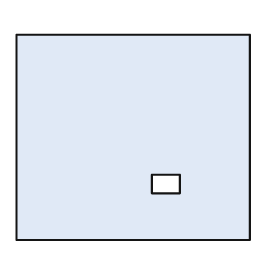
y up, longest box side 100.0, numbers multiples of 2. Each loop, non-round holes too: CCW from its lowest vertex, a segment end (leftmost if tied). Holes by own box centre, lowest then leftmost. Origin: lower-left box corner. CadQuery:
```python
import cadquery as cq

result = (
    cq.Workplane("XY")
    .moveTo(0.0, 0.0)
    .lineTo(100.0, 0.0)
    .lineTo(100.0, 88.0)
    .lineTo(0.0, 88.0)
    .close()
    .moveTo(58.0, 20.0)
    .lineTo(70.0, 20.0)
    .lineTo(70.0, 28.0)
    .lineTo(58.0, 28.0)
    .close()
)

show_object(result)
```